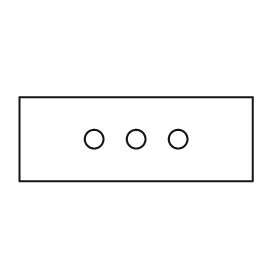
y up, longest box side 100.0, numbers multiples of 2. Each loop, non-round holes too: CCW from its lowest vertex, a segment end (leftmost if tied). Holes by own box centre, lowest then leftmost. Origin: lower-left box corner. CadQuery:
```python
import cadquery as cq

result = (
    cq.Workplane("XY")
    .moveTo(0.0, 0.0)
    .lineTo(100.0, 0.0)
    .lineTo(100.0, 36.0)
    .lineTo(0.0, 36.0)
    .close()
    .moveTo(32.0, 18.0)
    .circle(4.0)
    .moveTo(50.0, 18.0)
    .circle(4.0)
    .moveTo(68.0, 18.0)
    .circle(4.0)
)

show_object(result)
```